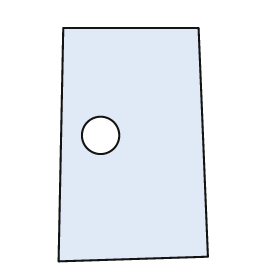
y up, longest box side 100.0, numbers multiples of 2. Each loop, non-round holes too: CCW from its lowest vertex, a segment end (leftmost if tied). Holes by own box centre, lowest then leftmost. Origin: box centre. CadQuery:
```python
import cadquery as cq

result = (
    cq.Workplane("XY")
    .moveTo(-32.0, -50.0)
    .lineTo(32.0, -48.0)
    .lineTo(28.0, 50.0)
    .lineTo(-30.0, 50.0)
    .close()
    .moveTo(-14.0, 4.0)
    .circle(8.0)
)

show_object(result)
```